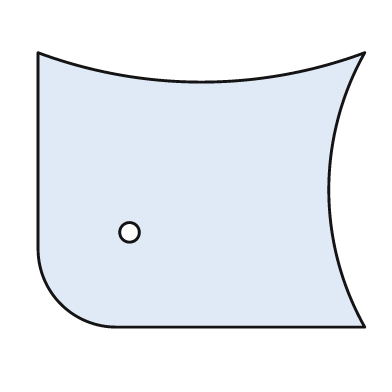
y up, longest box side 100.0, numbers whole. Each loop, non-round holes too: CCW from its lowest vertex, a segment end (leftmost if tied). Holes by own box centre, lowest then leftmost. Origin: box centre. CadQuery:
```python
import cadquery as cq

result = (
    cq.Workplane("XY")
    .moveTo(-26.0, -42.0)
    .lineTo(50.0, -42.0)
    .threePointArc((39.0, 0.0), (50.0, 42.0))
    .threePointArc((0.0, 33.0), (-50.0, 42.0))
    .lineTo(-50.0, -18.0)
    .threePointArc((-43.0, -35.0), (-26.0, -42.0))
    .close()
    .moveTo(-22.0, -13.0)
    .circle(3.0)
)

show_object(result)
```